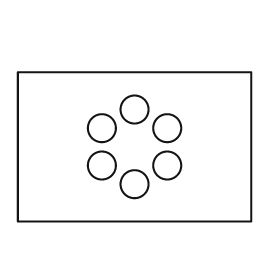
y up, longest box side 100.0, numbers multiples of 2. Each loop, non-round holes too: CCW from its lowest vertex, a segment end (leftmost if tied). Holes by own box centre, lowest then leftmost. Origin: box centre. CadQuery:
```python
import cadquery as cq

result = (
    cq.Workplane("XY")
    .moveTo(-50.0, -32.0)
    .lineTo(50.0, -32.0)
    .lineTo(50.0, 32.0)
    .lineTo(-50.0, 32.0)
    .close()
    .moveTo(0.0, -16.0)
    .circle(6.0)
    .moveTo(-14.0, -8.0)
    .circle(6.0)
    .moveTo(14.0, -8.0)
    .circle(6.0)
    .moveTo(-14.0, 8.0)
    .circle(6.0)
    .moveTo(14.0, 8.0)
    .circle(6.0)
    .moveTo(0.0, 16.0)
    .circle(6.0)
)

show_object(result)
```